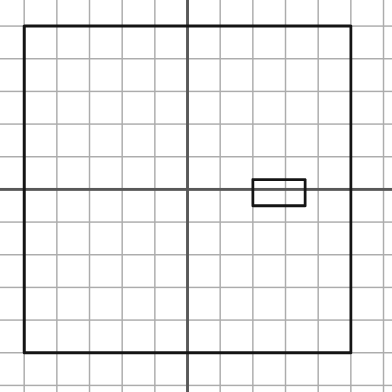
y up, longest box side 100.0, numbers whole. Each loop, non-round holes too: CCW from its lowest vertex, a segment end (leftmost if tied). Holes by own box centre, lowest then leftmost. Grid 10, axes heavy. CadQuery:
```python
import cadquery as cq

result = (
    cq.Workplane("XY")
    .moveTo(-50.0, -50.0)
    .lineTo(50.0, -50.0)
    .lineTo(50.0, 50.0)
    .lineTo(-50.0, 50.0)
    .close()
    .moveTo(20.0, -5.0)
    .lineTo(36.0, -5.0)
    .lineTo(36.0, 3.0)
    .lineTo(20.0, 3.0)
    .close()
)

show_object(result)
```